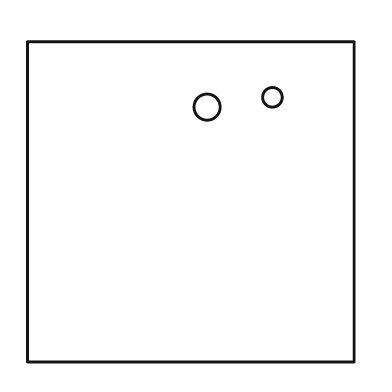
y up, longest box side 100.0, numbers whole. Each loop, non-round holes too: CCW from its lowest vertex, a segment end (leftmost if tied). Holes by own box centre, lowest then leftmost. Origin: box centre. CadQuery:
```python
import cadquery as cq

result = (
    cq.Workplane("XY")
    .moveTo(-50.0, -49.0)
    .lineTo(50.0, -49.0)
    .lineTo(50.0, 49.0)
    .lineTo(-50.0, 49.0)
    .close()
    .moveTo(5.0, 29.0)
    .circle(4.0)
    .moveTo(25.0, 32.0)
    .circle(3.0)
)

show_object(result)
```